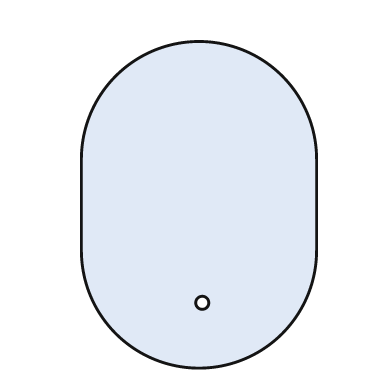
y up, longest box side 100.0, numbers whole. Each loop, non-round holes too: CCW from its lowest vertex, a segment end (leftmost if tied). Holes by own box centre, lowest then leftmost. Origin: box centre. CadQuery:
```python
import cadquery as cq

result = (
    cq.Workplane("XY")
    .moveTo(-36.0, -14.0)
    .threePointArc((0.0, -50.0), (36.0, -14.0))
    .lineTo(36.0, 14.0)
    .threePointArc((0.0, 50.0), (-36.0, 14.0))
    .close()
    .moveTo(1.0, -30.0)
    .circle(2.0)
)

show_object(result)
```